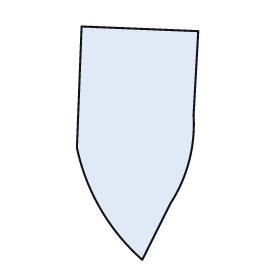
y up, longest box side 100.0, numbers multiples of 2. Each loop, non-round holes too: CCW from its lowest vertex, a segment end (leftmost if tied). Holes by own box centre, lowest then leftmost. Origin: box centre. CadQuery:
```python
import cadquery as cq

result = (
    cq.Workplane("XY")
    .moveTo(2.0, -50.0)
    .lineTo(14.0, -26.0)
    .threePointArc((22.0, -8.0), (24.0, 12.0))
    .lineTo(26.0, 48.0)
    .lineTo(-24.0, 50.0)
    .lineTo(-26.0, -2.0)
    .threePointArc((-16.0, -28.0), (2.0, -50.0))
    .close()
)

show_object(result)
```